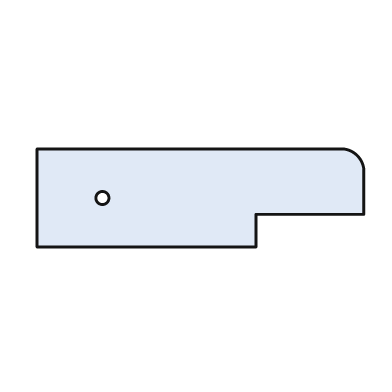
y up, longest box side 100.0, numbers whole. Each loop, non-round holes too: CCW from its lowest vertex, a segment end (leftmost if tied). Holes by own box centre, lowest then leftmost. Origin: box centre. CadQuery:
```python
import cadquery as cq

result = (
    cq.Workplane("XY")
    .moveTo(-50.0, -15.0)
    .lineTo(17.0, -15.0)
    .lineTo(17.0, -5.0)
    .lineTo(50.0, -5.0)
    .lineTo(50.0, 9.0)
    .threePointArc((48.0, 13.0), (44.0, 15.0))
    .lineTo(-50.0, 15.0)
    .close()
    .moveTo(-30.0, 0.0)
    .circle(2.0)
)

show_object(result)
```